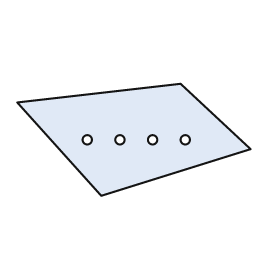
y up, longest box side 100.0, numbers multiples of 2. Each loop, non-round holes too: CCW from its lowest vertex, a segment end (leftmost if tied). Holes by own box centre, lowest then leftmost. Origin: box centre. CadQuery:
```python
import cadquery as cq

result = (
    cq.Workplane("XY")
    .moveTo(-14.0, -24.0)
    .lineTo(50.0, -4.0)
    .lineTo(20.0, 24.0)
    .lineTo(-50.0, 16.0)
    .close()
    .moveTo(-20.0, 0.0)
    .circle(2.0)
    .moveTo(-6.0, 0.0)
    .circle(2.0)
    .moveTo(8.0, 0.0)
    .circle(2.0)
    .moveTo(22.0, 0.0)
    .circle(2.0)
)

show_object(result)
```